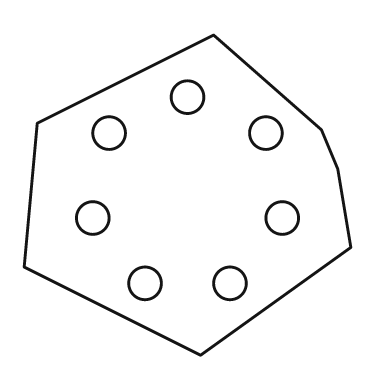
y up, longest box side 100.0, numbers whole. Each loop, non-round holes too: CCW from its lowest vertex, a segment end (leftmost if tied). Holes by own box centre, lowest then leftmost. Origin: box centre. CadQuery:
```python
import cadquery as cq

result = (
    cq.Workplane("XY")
    .moveTo(4.0, -49.0)
    .lineTo(50.0, -16.0)
    .lineTo(46.0, 8.0)
    .lineTo(41.0, 20.0)
    .lineTo(8.0, 49.0)
    .lineTo(-46.0, 22.0)
    .lineTo(-50.0, -22.0)
    .close()
    .moveTo(-13.0, -27.0)
    .circle(5.0)
    .moveTo(13.0, -27.0)
    .circle(5.0)
    .moveTo(-29.0, -7.0)
    .circle(5.0)
    .moveTo(29.0, -7.0)
    .circle(5.0)
    .moveTo(-24.0, 19.0)
    .circle(5.0)
    .moveTo(24.0, 19.0)
    .circle(5.0)
    .moveTo(0.0, 30.0)
    .circle(5.0)
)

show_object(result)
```